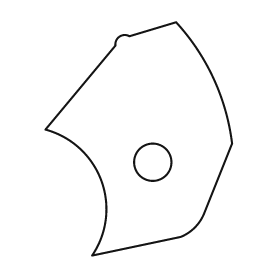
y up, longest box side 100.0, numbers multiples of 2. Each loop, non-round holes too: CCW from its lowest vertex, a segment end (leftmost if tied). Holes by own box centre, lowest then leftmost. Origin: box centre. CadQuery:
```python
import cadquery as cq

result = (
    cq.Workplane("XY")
    .moveTo(-20.0, -50.0)
    .lineTo(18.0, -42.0)
    .threePointArc((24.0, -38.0), (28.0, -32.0))
    .lineTo(40.0, -2.0)
    .threePointArc((32.0, 26.0), (16.0, 50.0))
    .lineTo(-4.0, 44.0)
    .threePointArc((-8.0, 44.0), (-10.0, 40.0))
    .lineTo(-40.0, 4.0)
    .threePointArc((-16.0, -18.0), (-20.0, -50.0))
    .close()
    .moveTo(6.0, -10.0)
    .circle(8.0)
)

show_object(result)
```